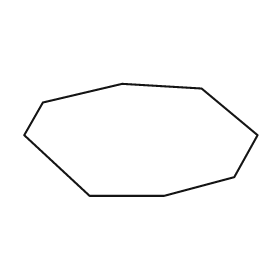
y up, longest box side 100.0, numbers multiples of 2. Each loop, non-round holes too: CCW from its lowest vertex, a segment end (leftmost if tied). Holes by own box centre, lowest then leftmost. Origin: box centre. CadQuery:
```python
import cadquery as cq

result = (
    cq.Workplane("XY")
    .moveTo(-22.0, -24.0)
    .lineTo(10.0, -24.0)
    .lineTo(40.0, -16.0)
    .lineTo(50.0, 2.0)
    .lineTo(26.0, 22.0)
    .lineTo(-8.0, 24.0)
    .lineTo(-42.0, 16.0)
    .lineTo(-50.0, 2.0)
    .close()
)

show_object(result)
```